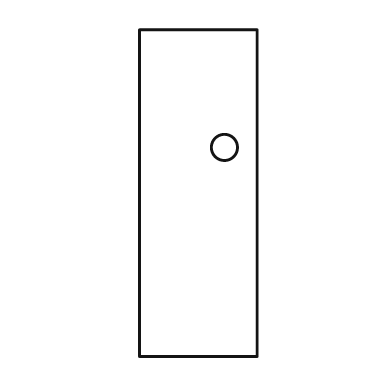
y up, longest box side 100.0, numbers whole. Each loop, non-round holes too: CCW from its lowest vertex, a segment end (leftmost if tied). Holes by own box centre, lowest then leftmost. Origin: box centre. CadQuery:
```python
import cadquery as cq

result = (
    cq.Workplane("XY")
    .moveTo(-18.0, -50.0)
    .lineTo(18.0, -50.0)
    .lineTo(18.0, 50.0)
    .lineTo(-18.0, 50.0)
    .close()
    .moveTo(8.0, 14.0)
    .circle(4.0)
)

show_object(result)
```